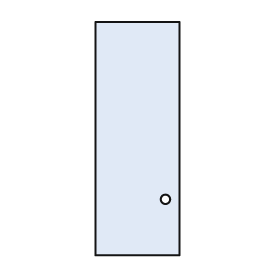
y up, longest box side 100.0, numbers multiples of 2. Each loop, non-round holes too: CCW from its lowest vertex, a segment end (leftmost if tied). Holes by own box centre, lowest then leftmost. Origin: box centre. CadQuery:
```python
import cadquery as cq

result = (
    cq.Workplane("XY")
    .moveTo(-18.0, -50.0)
    .lineTo(18.0, -50.0)
    .lineTo(18.0, 50.0)
    .lineTo(-18.0, 50.0)
    .close()
    .moveTo(12.0, -26.0)
    .circle(2.0)
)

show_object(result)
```